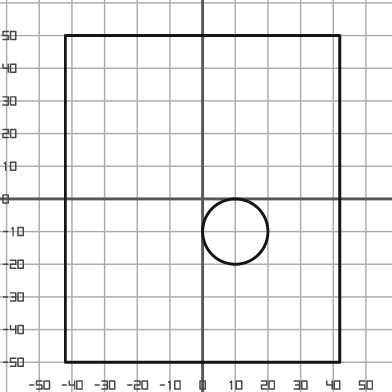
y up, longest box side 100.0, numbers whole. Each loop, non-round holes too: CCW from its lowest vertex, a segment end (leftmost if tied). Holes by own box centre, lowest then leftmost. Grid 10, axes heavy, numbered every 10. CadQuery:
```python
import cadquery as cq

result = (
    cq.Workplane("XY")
    .moveTo(-42.0, -50.0)
    .lineTo(42.0, -50.0)
    .lineTo(42.0, 50.0)
    .lineTo(-42.0, 50.0)
    .close()
    .moveTo(10.0, -10.0)
    .circle(10.0)
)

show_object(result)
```